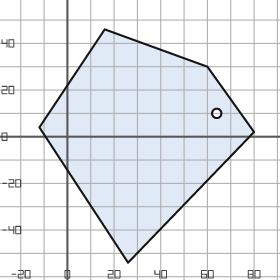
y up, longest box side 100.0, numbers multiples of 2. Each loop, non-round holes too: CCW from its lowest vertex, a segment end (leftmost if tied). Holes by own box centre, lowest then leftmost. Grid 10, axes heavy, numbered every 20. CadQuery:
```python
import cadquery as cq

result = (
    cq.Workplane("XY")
    .moveTo(26.0, -54.0)
    .lineTo(80.0, 2.0)
    .lineTo(60.0, 30.0)
    .lineTo(16.0, 46.0)
    .lineTo(-12.0, 4.0)
    .close()
    .moveTo(64.0, 10.0)
    .circle(2.0)
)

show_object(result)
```